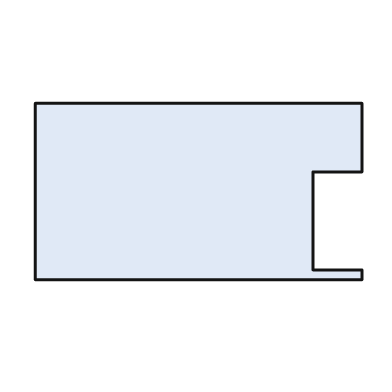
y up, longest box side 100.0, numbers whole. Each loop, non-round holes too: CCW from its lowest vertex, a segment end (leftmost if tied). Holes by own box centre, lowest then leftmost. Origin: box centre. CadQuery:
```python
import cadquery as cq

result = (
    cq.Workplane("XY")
    .moveTo(-50.0, -27.0)
    .lineTo(50.0, -27.0)
    .lineTo(50.0, -24.0)
    .lineTo(35.0, -24.0)
    .lineTo(35.0, 6.0)
    .lineTo(50.0, 6.0)
    .lineTo(50.0, 27.0)
    .lineTo(-50.0, 27.0)
    .close()
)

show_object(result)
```